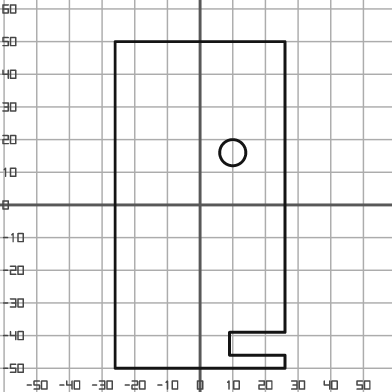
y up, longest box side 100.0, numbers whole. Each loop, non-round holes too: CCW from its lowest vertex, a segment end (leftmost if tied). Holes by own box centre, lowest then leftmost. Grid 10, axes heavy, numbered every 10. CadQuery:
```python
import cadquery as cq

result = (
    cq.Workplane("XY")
    .moveTo(-26.0, -50.0)
    .lineTo(26.0, -50.0)
    .lineTo(26.0, -46.0)
    .lineTo(9.0, -46.0)
    .lineTo(9.0, -39.0)
    .lineTo(26.0, -39.0)
    .lineTo(26.0, 50.0)
    .lineTo(-26.0, 50.0)
    .close()
    .moveTo(10.0, 16.0)
    .circle(4.0)
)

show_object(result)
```